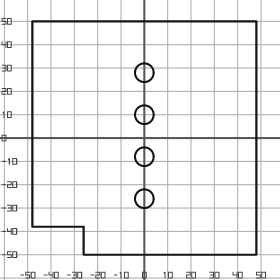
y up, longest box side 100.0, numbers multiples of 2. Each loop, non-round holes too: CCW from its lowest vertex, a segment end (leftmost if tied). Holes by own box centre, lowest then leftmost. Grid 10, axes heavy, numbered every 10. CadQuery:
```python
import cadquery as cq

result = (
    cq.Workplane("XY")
    .moveTo(-26.0, -50.0)
    .lineTo(48.0, -50.0)
    .lineTo(48.0, 50.0)
    .lineTo(-48.0, 50.0)
    .lineTo(-48.0, -38.0)
    .lineTo(-26.0, -38.0)
    .close()
    .moveTo(0.0, -26.0)
    .circle(4.0)
    .moveTo(0.0, -8.0)
    .circle(4.0)
    .moveTo(0.0, 10.0)
    .circle(4.0)
    .moveTo(0.0, 28.0)
    .circle(4.0)
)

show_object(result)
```